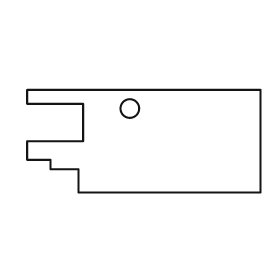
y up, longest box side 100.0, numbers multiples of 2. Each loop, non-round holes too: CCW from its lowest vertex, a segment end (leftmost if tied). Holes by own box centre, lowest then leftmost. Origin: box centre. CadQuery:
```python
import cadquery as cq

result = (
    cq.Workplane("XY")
    .moveTo(-28.0, -22.0)
    .lineTo(50.0, -22.0)
    .lineTo(50.0, 22.0)
    .lineTo(-50.0, 22.0)
    .lineTo(-50.0, 16.0)
    .lineTo(-26.0, 16.0)
    .lineTo(-26.0, 0.0)
    .lineTo(-50.0, 0.0)
    .lineTo(-50.0, -8.0)
    .lineTo(-40.0, -8.0)
    .lineTo(-40.0, -12.0)
    .lineTo(-28.0, -12.0)
    .close()
    .moveTo(-6.0, 14.0)
    .circle(4.0)
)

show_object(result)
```